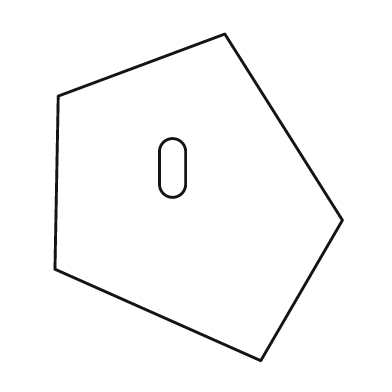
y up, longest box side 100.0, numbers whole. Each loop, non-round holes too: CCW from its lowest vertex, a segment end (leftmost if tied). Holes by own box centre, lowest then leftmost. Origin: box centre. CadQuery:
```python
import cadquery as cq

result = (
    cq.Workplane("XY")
    .moveTo(19.0, -50.0)
    .lineTo(44.0, -7.0)
    .lineTo(8.0, 50.0)
    .lineTo(-43.0, 31.0)
    .lineTo(-44.0, -22.0)
    .close()
    .moveTo(-12.0, 4.0)
    .threePointArc((-8.0, 0.0), (-4.0, 4.0))
    .lineTo(-4.0, 14.0)
    .threePointArc((-8.0, 18.0), (-12.0, 14.0))
    .close()
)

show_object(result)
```